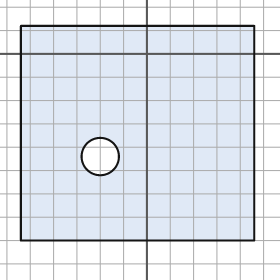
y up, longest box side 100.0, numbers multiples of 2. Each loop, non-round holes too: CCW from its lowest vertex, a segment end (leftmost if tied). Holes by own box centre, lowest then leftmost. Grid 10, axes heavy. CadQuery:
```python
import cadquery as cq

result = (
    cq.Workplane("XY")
    .moveTo(-54.0, -80.0)
    .lineTo(46.0, -80.0)
    .lineTo(46.0, 12.0)
    .lineTo(-54.0, 12.0)
    .close()
    .moveTo(-20.0, -44.0)
    .circle(8.0)
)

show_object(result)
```